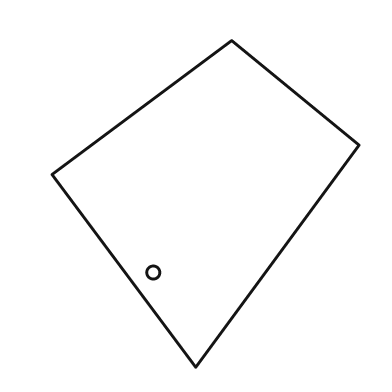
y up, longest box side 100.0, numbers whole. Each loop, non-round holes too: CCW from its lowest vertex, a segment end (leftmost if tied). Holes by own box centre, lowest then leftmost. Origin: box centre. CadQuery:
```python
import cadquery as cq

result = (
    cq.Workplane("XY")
    .moveTo(-3.0, -50.0)
    .lineTo(47.0, 18.0)
    .lineTo(8.0, 50.0)
    .lineTo(-47.0, 9.0)
    .close()
    .moveTo(-16.0, -21.0)
    .circle(2.0)
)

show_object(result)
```